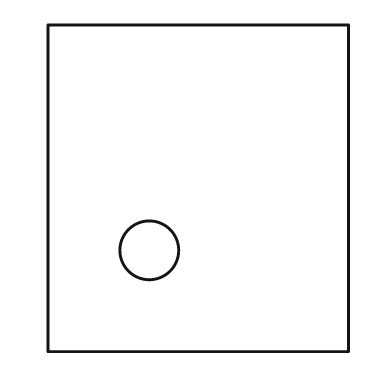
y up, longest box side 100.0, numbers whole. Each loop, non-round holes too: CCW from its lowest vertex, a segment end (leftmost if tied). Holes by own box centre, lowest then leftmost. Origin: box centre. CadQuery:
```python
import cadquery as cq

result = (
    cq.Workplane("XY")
    .moveTo(-46.0, -50.0)
    .lineTo(46.0, -50.0)
    .lineTo(46.0, 50.0)
    .lineTo(-46.0, 50.0)
    .close()
    .moveTo(-15.0, -19.0)
    .circle(9.0)
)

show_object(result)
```